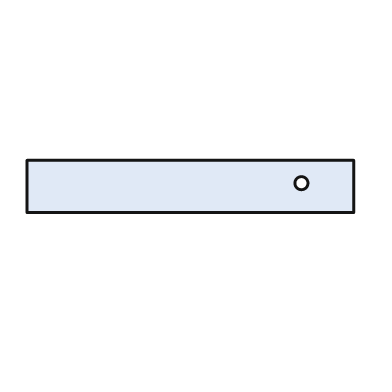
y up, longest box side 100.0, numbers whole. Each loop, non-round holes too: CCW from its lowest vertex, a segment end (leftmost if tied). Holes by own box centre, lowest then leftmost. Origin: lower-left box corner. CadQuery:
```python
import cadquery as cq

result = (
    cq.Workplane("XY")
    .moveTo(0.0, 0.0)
    .lineTo(100.0, 0.0)
    .lineTo(100.0, 16.0)
    .lineTo(0.0, 16.0)
    .close()
    .moveTo(84.0, 9.0)
    .circle(2.0)
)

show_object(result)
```